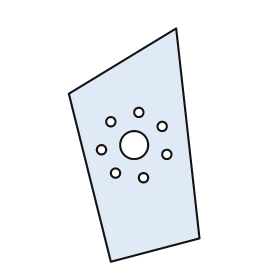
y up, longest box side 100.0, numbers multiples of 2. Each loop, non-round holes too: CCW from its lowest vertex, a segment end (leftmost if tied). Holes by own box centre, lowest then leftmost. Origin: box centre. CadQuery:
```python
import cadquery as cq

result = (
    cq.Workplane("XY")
    .moveTo(-10.0, -50.0)
    .lineTo(28.0, -40.0)
    .lineTo(18.0, 50.0)
    .lineTo(-28.0, 22.0)
    .close()
    .moveTo(4.0, -14.0)
    .circle(2.0)
    .moveTo(-8.0, -12.0)
    .circle(2.0)
    .moveTo(14.0, -4.0)
    .circle(2.0)
    .moveTo(-14.0, -2.0)
    .circle(2.0)
    .moveTo(0.0, 0.0)
    .circle(6.0)
    .moveTo(12.0, 8.0)
    .circle(2.0)
    .moveTo(-10.0, 10.0)
    .circle(2.0)
    .moveTo(2.0, 14.0)
    .circle(2.0)
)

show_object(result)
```